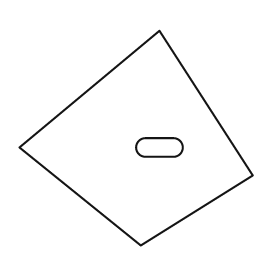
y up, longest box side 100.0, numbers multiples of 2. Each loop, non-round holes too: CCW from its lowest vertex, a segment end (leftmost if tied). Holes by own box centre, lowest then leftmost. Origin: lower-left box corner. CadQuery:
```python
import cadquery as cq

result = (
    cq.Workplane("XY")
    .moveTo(52.0, 0.0)
    .lineTo(100.0, 30.0)
    .lineTo(60.0, 92.0)
    .lineTo(0.0, 42.0)
    .close()
    .moveTo(54.0, 38.0)
    .lineTo(66.0, 38.0)
    .threePointArc((70.0, 42.0), (66.0, 46.0))
    .lineTo(54.0, 46.0)
    .threePointArc((50.0, 42.0), (54.0, 38.0))
    .close()
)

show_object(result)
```